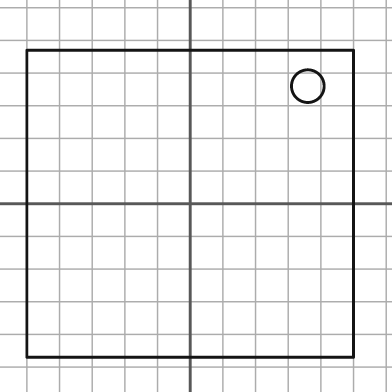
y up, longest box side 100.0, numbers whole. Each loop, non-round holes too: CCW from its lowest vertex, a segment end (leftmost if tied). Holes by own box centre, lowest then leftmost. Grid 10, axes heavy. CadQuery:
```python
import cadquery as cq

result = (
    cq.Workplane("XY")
    .moveTo(-50.0, -47.0)
    .lineTo(50.0, -47.0)
    .lineTo(50.0, 47.0)
    .lineTo(-50.0, 47.0)
    .close()
    .moveTo(36.0, 36.0)
    .circle(5.0)
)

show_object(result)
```